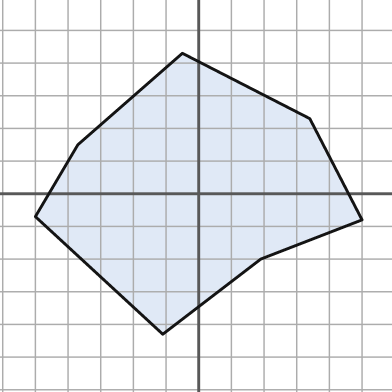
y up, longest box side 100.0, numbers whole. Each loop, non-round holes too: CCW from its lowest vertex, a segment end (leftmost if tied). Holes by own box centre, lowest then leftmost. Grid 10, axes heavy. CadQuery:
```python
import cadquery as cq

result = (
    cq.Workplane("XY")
    .moveTo(-11.0, -43.0)
    .lineTo(19.0, -20.0)
    .lineTo(50.0, -8.0)
    .lineTo(34.0, 23.0)
    .lineTo(-5.0, 43.0)
    .lineTo(-37.0, 15.0)
    .lineTo(-50.0, -7.0)
    .close()
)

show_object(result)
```